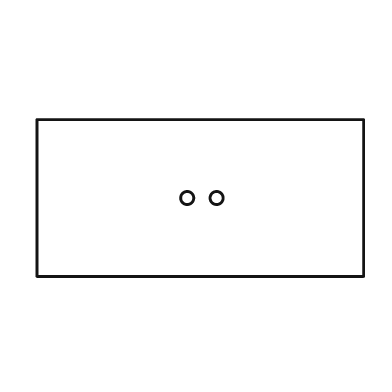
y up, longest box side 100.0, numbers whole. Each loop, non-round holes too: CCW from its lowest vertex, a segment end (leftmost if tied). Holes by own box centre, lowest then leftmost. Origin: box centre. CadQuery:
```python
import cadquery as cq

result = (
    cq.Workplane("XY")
    .moveTo(-50.0, -24.0)
    .lineTo(50.0, -24.0)
    .lineTo(50.0, 24.0)
    .lineTo(-50.0, 24.0)
    .close()
    .moveTo(-4.0, 0.0)
    .circle(2.0)
    .moveTo(5.0, 0.0)
    .circle(2.0)
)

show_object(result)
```